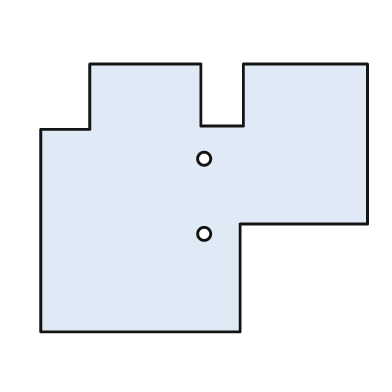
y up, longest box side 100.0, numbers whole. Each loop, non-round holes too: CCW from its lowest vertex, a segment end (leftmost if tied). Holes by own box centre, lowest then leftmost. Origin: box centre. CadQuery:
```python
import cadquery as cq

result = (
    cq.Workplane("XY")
    .moveTo(-50.0, -41.0)
    .lineTo(11.0, -41.0)
    .lineTo(11.0, -8.0)
    .lineTo(50.0, -8.0)
    .lineTo(50.0, 41.0)
    .lineTo(12.0, 41.0)
    .lineTo(12.0, 22.0)
    .lineTo(-1.0, 22.0)
    .lineTo(-1.0, 41.0)
    .lineTo(-35.0, 41.0)
    .lineTo(-35.0, 21.0)
    .lineTo(-50.0, 21.0)
    .close()
    .moveTo(0.0, -11.0)
    .circle(2.0)
    .moveTo(0.0, 12.0)
    .circle(2.0)
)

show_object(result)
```